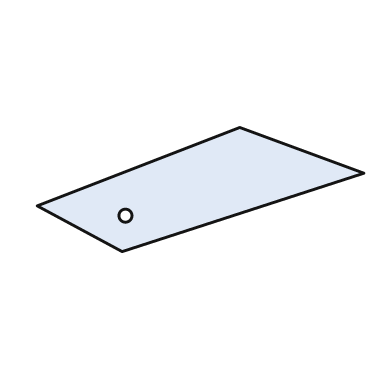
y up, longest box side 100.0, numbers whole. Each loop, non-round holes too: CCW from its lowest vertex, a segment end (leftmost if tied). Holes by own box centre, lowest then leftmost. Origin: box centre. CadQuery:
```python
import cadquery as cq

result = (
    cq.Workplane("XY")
    .moveTo(-24.0, -19.0)
    .lineTo(50.0, 5.0)
    .lineTo(12.0, 19.0)
    .lineTo(-50.0, -5.0)
    .close()
    .moveTo(-23.0, -8.0)
    .circle(2.0)
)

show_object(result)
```